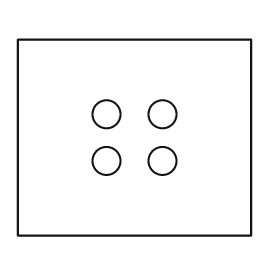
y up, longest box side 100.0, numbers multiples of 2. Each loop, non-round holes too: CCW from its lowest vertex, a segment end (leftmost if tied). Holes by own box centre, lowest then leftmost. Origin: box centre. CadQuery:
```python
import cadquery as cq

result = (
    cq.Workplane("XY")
    .moveTo(-50.0, -42.0)
    .lineTo(50.0, -42.0)
    .lineTo(50.0, 42.0)
    .lineTo(-50.0, 42.0)
    .close()
    .moveTo(-12.0, -10.0)
    .circle(6.0)
    .moveTo(12.0, -10.0)
    .circle(6.0)
    .moveTo(-12.0, 10.0)
    .circle(6.0)
    .moveTo(12.0, 10.0)
    .circle(6.0)
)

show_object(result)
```